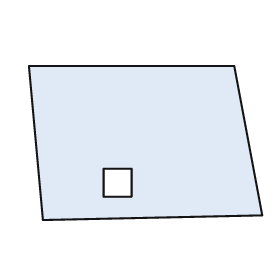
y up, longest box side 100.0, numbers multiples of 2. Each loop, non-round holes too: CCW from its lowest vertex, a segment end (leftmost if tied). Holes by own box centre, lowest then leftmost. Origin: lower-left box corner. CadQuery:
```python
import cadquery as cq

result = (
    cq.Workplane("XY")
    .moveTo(6.0, 0.0)
    .lineTo(100.0, 2.0)
    .lineTo(88.0, 66.0)
    .lineTo(0.0, 66.0)
    .close()
    .moveTo(32.0, 10.0)
    .lineTo(44.0, 10.0)
    .lineTo(44.0, 22.0)
    .lineTo(32.0, 22.0)
    .close()
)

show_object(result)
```